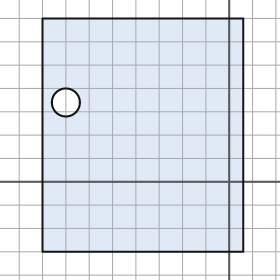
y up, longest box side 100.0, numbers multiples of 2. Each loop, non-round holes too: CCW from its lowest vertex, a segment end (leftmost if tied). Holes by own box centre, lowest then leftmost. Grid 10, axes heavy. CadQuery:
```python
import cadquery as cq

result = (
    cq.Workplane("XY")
    .moveTo(-80.0, -30.0)
    .lineTo(6.0, -30.0)
    .lineTo(6.0, 70.0)
    .lineTo(-80.0, 70.0)
    .close()
    .moveTo(-70.0, 34.0)
    .circle(6.0)
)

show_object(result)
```